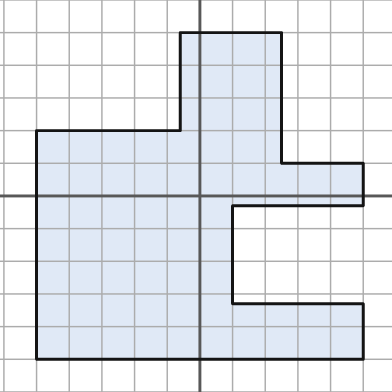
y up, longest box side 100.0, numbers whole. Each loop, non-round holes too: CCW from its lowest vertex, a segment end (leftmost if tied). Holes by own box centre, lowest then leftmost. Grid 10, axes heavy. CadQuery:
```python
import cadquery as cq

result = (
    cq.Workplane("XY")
    .moveTo(-50.0, -50.0)
    .lineTo(50.0, -50.0)
    .lineTo(50.0, -33.0)
    .lineTo(10.0, -33.0)
    .lineTo(10.0, -3.0)
    .lineTo(50.0, -3.0)
    .lineTo(50.0, 10.0)
    .lineTo(25.0, 10.0)
    .lineTo(25.0, 50.0)
    .lineTo(-6.0, 50.0)
    .lineTo(-6.0, 20.0)
    .lineTo(-50.0, 20.0)
    .close()
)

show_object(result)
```